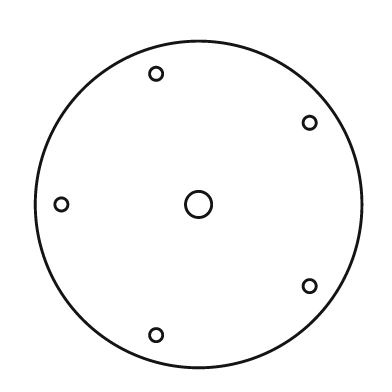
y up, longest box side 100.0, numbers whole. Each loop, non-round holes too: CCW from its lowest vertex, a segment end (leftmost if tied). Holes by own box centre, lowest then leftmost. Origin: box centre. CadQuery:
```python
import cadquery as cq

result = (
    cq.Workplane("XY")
    .moveTo(0.0, 0.0)
    .circle(50.0)
    .moveTo(-13.0, -40.0)
    .circle(2.0)
    .moveTo(34.0, -25.0)
    .circle(2.0)
    .moveTo(-42.0, 0.0)
    .circle(2.0)
    .moveTo(0.0, 0.0)
    .circle(4.0)
    .moveTo(34.0, 25.0)
    .circle(2.0)
    .moveTo(-13.0, 40.0)
    .circle(2.0)
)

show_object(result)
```